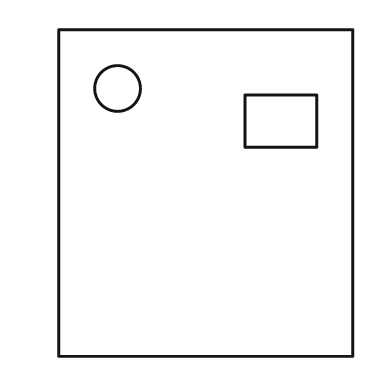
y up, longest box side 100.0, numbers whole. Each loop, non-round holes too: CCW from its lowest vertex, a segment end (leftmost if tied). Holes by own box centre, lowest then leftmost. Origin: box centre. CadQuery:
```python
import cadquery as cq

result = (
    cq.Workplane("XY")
    .moveTo(-45.0, -50.0)
    .lineTo(45.0, -50.0)
    .lineTo(45.0, 50.0)
    .lineTo(-45.0, 50.0)
    .close()
    .moveTo(12.0, 14.0)
    .lineTo(34.0, 14.0)
    .lineTo(34.0, 30.0)
    .lineTo(12.0, 30.0)
    .close()
    .moveTo(-27.0, 32.0)
    .circle(7.0)
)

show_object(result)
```